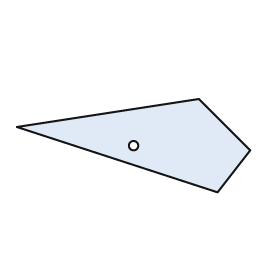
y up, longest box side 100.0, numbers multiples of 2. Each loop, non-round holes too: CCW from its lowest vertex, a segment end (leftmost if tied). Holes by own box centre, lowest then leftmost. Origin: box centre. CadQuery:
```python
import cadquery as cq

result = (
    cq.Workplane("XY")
    .moveTo(36.0, -20.0)
    .lineTo(50.0, -2.0)
    .lineTo(28.0, 20.0)
    .lineTo(-50.0, 8.0)
    .close()
    .moveTo(0.0, 0.0)
    .circle(2.0)
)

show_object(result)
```